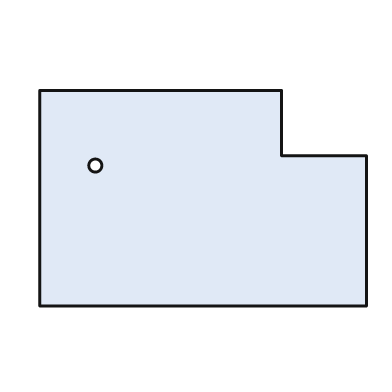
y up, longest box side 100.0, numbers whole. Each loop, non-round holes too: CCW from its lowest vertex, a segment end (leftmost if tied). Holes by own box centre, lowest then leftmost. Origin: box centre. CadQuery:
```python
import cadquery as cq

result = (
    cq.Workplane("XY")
    .moveTo(-50.0, -33.0)
    .lineTo(50.0, -33.0)
    .lineTo(50.0, 13.0)
    .lineTo(24.0, 13.0)
    .lineTo(24.0, 33.0)
    .lineTo(-50.0, 33.0)
    .close()
    .moveTo(-33.0, 10.0)
    .circle(2.0)
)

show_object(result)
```